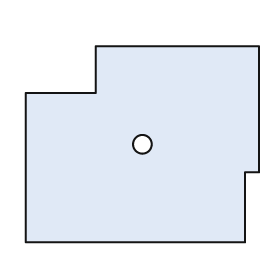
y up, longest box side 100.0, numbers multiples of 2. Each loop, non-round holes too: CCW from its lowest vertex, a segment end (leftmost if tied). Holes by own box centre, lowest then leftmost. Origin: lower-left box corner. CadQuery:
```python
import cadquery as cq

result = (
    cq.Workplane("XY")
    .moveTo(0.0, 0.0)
    .lineTo(94.0, 0.0)
    .lineTo(94.0, 30.0)
    .lineTo(100.0, 30.0)
    .lineTo(100.0, 84.0)
    .lineTo(30.0, 84.0)
    .lineTo(30.0, 64.0)
    .lineTo(0.0, 64.0)
    .close()
    .moveTo(50.0, 42.0)
    .circle(4.0)
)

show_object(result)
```